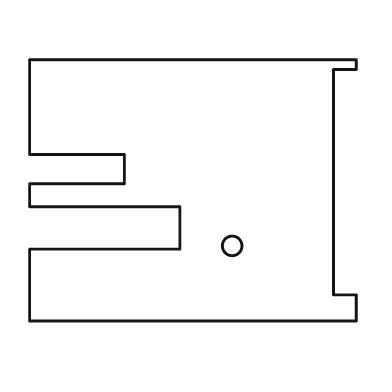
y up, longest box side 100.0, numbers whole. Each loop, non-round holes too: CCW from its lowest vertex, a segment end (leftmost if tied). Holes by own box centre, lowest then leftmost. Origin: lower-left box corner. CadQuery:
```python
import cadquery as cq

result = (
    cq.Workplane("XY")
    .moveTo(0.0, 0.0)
    .lineTo(100.0, 0.0)
    .lineTo(100.0, 8.0)
    .lineTo(93.0, 8.0)
    .lineTo(93.0, 77.0)
    .lineTo(100.0, 77.0)
    .lineTo(100.0, 80.0)
    .lineTo(0.0, 80.0)
    .lineTo(0.0, 51.0)
    .lineTo(29.0, 51.0)
    .lineTo(29.0, 42.0)
    .lineTo(0.0, 42.0)
    .lineTo(0.0, 35.0)
    .lineTo(46.0, 35.0)
    .lineTo(46.0, 22.0)
    .lineTo(0.0, 22.0)
    .close()
    .moveTo(62.0, 23.0)
    .circle(3.0)
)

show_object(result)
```